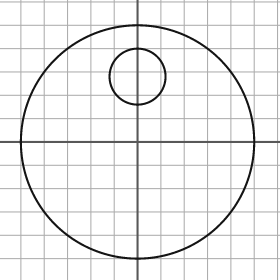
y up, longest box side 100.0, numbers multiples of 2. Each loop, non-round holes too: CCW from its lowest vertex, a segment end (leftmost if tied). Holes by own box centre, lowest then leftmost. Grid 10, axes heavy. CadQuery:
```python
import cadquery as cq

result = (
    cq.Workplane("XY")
    .moveTo(0.0, 0.0)
    .circle(50.0)
    .moveTo(0.0, 28.0)
    .circle(12.0)
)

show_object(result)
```